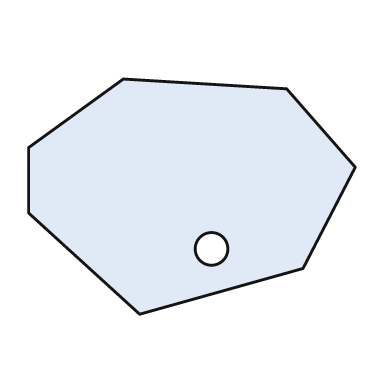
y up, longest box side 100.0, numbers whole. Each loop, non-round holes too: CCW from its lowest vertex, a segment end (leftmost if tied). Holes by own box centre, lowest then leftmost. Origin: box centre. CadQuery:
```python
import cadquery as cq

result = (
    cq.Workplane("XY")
    .moveTo(-16.0, -36.0)
    .lineTo(34.0, -22.0)
    .lineTo(50.0, 9.0)
    .lineTo(29.0, 33.0)
    .lineTo(-21.0, 36.0)
    .lineTo(-50.0, 15.0)
    .lineTo(-50.0, -5.0)
    .close()
    .moveTo(6.0, -16.0)
    .circle(5.0)
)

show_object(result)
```